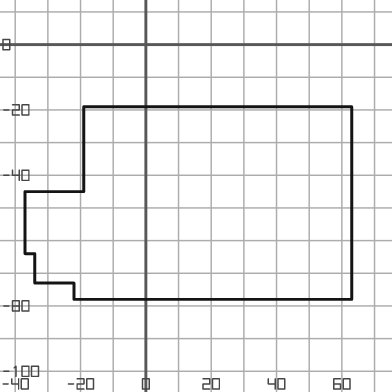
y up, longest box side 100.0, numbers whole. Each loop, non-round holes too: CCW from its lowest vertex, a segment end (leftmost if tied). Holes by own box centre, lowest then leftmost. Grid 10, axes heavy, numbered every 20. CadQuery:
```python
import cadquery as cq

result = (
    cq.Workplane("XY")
    .moveTo(-22.0, -78.0)
    .lineTo(63.0, -78.0)
    .lineTo(63.0, -19.0)
    .lineTo(-19.0, -19.0)
    .lineTo(-19.0, -45.0)
    .lineTo(-37.0, -45.0)
    .lineTo(-37.0, -64.0)
    .lineTo(-34.0, -64.0)
    .lineTo(-34.0, -73.0)
    .lineTo(-22.0, -73.0)
    .close()
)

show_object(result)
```